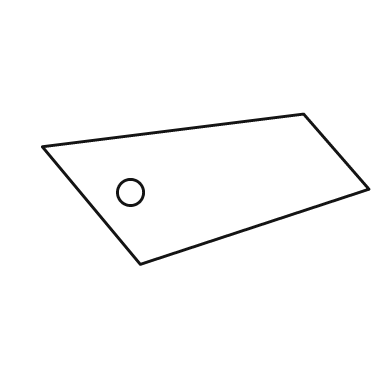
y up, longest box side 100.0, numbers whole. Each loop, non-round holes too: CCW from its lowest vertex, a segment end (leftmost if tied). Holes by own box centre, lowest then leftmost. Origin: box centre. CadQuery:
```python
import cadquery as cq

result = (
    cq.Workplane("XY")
    .moveTo(-20.0, -23.0)
    .lineTo(50.0, 0.0)
    .lineTo(30.0, 23.0)
    .lineTo(-50.0, 13.0)
    .close()
    .moveTo(-23.0, -1.0)
    .circle(4.0)
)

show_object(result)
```